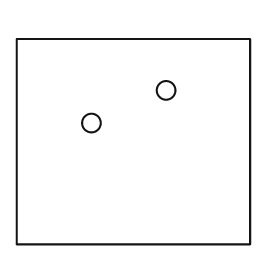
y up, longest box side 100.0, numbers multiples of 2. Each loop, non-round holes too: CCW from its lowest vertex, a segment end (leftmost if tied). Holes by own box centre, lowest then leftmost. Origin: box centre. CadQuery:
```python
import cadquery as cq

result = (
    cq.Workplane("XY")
    .moveTo(-50.0, -44.0)
    .lineTo(50.0, -44.0)
    .lineTo(50.0, 44.0)
    .lineTo(-50.0, 44.0)
    .close()
    .moveTo(-18.0, 8.0)
    .circle(4.0)
    .moveTo(14.0, 22.0)
    .circle(4.0)
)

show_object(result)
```